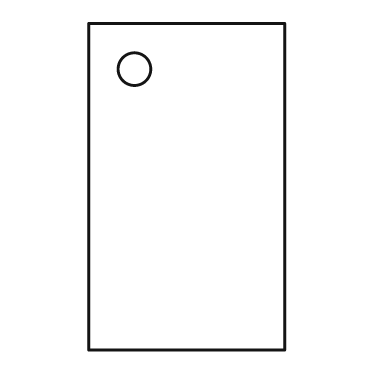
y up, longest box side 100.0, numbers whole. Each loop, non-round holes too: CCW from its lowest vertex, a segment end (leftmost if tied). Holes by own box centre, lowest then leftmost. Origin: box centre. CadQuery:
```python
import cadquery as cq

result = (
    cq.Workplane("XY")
    .moveTo(-30.0, -50.0)
    .lineTo(30.0, -50.0)
    .lineTo(30.0, 50.0)
    .lineTo(-30.0, 50.0)
    .close()
    .moveTo(-16.0, 36.0)
    .circle(5.0)
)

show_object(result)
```